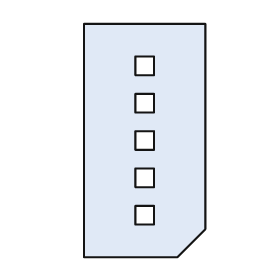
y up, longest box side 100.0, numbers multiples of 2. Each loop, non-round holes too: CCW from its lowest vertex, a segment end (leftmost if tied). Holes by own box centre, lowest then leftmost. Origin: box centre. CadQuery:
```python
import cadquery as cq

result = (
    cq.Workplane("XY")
    .moveTo(-26.0, -50.0)
    .lineTo(14.0, -50.0)
    .lineTo(26.0, -38.0)
    .lineTo(26.0, 50.0)
    .lineTo(-26.0, 50.0)
    .close()
    .moveTo(-4.0, -36.0)
    .lineTo(4.0, -36.0)
    .lineTo(4.0, -28.0)
    .lineTo(-4.0, -28.0)
    .close()
    .moveTo(-4.0, -20.0)
    .lineTo(4.0, -20.0)
    .lineTo(4.0, -12.0)
    .lineTo(-4.0, -12.0)
    .close()
    .moveTo(-4.0, -4.0)
    .lineTo(4.0, -4.0)
    .lineTo(4.0, 4.0)
    .lineTo(-4.0, 4.0)
    .close()
    .moveTo(-4.0, 12.0)
    .lineTo(4.0, 12.0)
    .lineTo(4.0, 20.0)
    .lineTo(-4.0, 20.0)
    .close()
    .moveTo(-4.0, 28.0)
    .lineTo(4.0, 28.0)
    .lineTo(4.0, 36.0)
    .lineTo(-4.0, 36.0)
    .close()
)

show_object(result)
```